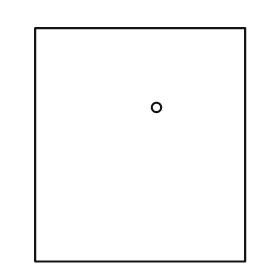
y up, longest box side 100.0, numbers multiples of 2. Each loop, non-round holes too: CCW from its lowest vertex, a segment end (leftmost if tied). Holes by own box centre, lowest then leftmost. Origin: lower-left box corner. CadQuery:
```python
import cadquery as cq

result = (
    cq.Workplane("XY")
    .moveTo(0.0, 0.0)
    .lineTo(90.0, 0.0)
    .lineTo(90.0, 100.0)
    .lineTo(0.0, 100.0)
    .close()
    .moveTo(52.0, 66.0)
    .circle(2.0)
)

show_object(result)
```